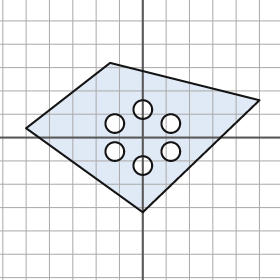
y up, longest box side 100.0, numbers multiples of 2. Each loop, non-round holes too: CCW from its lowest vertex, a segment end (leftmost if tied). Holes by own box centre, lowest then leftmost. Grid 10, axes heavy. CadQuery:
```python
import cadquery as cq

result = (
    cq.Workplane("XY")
    .moveTo(0.0, -32.0)
    .lineTo(50.0, 16.0)
    .lineTo(-14.0, 32.0)
    .lineTo(-50.0, 4.0)
    .close()
    .moveTo(0.0, -12.0)
    .circle(4.0)
    .moveTo(-12.0, -6.0)
    .circle(4.0)
    .moveTo(12.0, -6.0)
    .circle(4.0)
    .moveTo(-12.0, 6.0)
    .circle(4.0)
    .moveTo(12.0, 6.0)
    .circle(4.0)
    .moveTo(0.0, 12.0)
    .circle(4.0)
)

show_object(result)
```